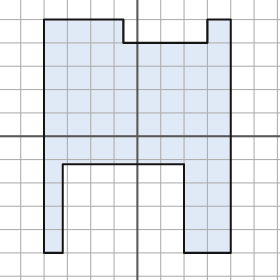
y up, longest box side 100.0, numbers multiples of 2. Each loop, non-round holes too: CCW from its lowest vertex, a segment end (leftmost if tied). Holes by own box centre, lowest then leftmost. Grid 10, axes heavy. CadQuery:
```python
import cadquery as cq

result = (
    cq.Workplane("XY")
    .moveTo(-40.0, -50.0)
    .lineTo(-32.0, -50.0)
    .lineTo(-32.0, -12.0)
    .lineTo(20.0, -12.0)
    .lineTo(20.0, -50.0)
    .lineTo(40.0, -50.0)
    .lineTo(40.0, 50.0)
    .lineTo(30.0, 50.0)
    .lineTo(30.0, 40.0)
    .lineTo(-6.0, 40.0)
    .lineTo(-6.0, 50.0)
    .lineTo(-40.0, 50.0)
    .close()
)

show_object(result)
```